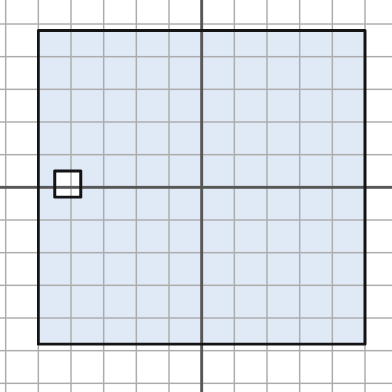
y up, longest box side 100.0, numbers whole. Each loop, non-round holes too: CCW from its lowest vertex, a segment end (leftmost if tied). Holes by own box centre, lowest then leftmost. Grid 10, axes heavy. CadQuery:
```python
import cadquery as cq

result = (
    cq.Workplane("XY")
    .moveTo(-50.0, -48.0)
    .lineTo(50.0, -48.0)
    .lineTo(50.0, 48.0)
    .lineTo(-50.0, 48.0)
    .close()
    .moveTo(-45.0, -3.0)
    .lineTo(-37.0, -3.0)
    .lineTo(-37.0, 5.0)
    .lineTo(-45.0, 5.0)
    .close()
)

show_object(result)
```